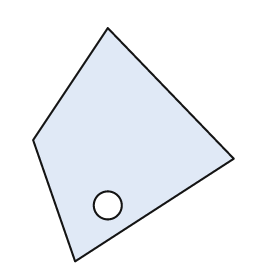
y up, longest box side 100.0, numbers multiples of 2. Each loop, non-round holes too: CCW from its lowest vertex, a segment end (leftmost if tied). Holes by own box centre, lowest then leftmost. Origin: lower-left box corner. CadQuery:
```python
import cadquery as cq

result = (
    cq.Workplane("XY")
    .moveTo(18.0, 0.0)
    .lineTo(86.0, 44.0)
    .lineTo(32.0, 100.0)
    .lineTo(0.0, 52.0)
    .close()
    .moveTo(32.0, 24.0)
    .circle(6.0)
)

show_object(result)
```